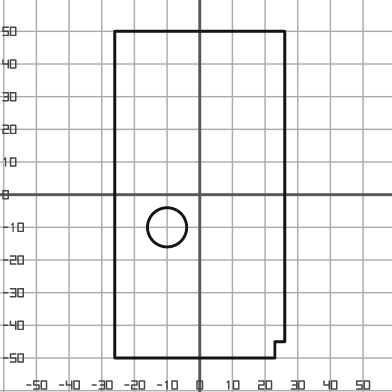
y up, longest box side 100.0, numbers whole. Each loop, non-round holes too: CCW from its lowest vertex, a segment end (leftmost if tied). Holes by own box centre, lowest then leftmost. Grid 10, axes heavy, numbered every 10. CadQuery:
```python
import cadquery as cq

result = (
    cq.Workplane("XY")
    .moveTo(-26.0, -50.0)
    .lineTo(23.0, -50.0)
    .lineTo(23.0, -45.0)
    .lineTo(26.0, -45.0)
    .lineTo(26.0, 50.0)
    .lineTo(-26.0, 50.0)
    .close()
    .moveTo(-10.0, -10.0)
    .circle(6.0)
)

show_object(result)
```